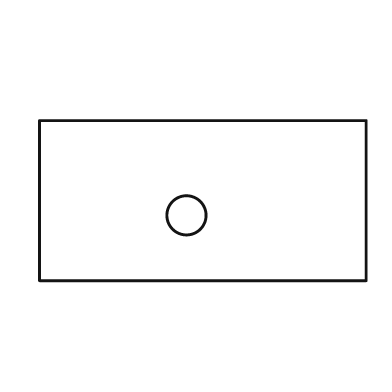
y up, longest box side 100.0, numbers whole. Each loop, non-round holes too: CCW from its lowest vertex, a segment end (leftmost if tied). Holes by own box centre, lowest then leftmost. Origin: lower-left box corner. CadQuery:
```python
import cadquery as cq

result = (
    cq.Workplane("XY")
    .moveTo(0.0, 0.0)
    .lineTo(100.0, 0.0)
    .lineTo(100.0, 49.0)
    .lineTo(0.0, 49.0)
    .close()
    .moveTo(45.0, 20.0)
    .circle(6.0)
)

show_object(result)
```